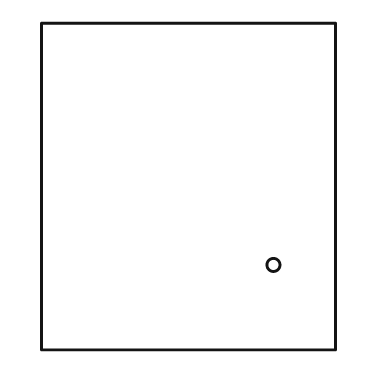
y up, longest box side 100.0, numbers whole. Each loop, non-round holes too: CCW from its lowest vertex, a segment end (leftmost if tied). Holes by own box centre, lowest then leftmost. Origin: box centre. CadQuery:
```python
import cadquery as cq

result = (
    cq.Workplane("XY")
    .moveTo(-45.0, -50.0)
    .lineTo(45.0, -50.0)
    .lineTo(45.0, 50.0)
    .lineTo(-45.0, 50.0)
    .close()
    .moveTo(26.0, -24.0)
    .circle(2.0)
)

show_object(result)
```